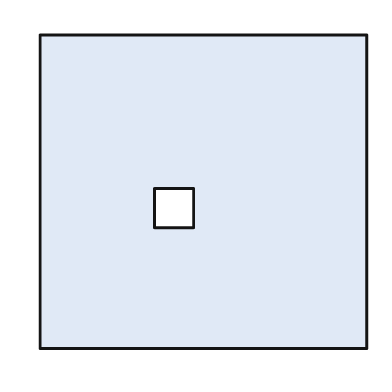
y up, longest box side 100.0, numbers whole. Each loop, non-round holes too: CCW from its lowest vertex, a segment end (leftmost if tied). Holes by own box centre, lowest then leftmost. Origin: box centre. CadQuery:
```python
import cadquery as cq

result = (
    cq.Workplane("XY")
    .moveTo(-50.0, -48.0)
    .lineTo(50.0, -48.0)
    .lineTo(50.0, 48.0)
    .lineTo(-50.0, 48.0)
    .close()
    .moveTo(-15.0, -11.0)
    .lineTo(-3.0, -11.0)
    .lineTo(-3.0, 1.0)
    .lineTo(-15.0, 1.0)
    .close()
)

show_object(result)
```